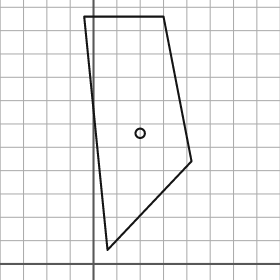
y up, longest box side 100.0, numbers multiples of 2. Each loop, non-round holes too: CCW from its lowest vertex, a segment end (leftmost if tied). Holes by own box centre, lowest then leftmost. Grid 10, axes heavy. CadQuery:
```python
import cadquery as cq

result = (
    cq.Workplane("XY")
    .moveTo(6.0, 6.0)
    .lineTo(42.0, 44.0)
    .lineTo(30.0, 106.0)
    .lineTo(-4.0, 106.0)
    .close()
    .moveTo(20.0, 56.0)
    .circle(2.0)
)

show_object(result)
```